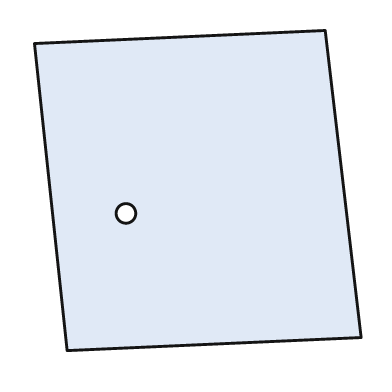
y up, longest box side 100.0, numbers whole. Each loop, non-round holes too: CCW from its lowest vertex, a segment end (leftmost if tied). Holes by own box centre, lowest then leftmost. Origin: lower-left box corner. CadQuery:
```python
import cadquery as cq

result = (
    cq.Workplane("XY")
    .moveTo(10.0, 0.0)
    .lineTo(100.0, 4.0)
    .lineTo(89.0, 98.0)
    .lineTo(0.0, 94.0)
    .close()
    .moveTo(28.0, 42.0)
    .circle(3.0)
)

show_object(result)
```